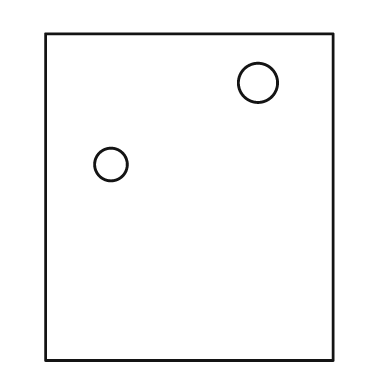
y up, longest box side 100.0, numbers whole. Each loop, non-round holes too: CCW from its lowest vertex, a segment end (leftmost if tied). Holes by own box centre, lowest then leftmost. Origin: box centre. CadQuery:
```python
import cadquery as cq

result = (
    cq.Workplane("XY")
    .moveTo(-44.0, -50.0)
    .lineTo(44.0, -50.0)
    .lineTo(44.0, 50.0)
    .lineTo(-44.0, 50.0)
    .close()
    .moveTo(-24.0, 10.0)
    .circle(5.0)
    .moveTo(21.0, 35.0)
    .circle(6.0)
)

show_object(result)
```